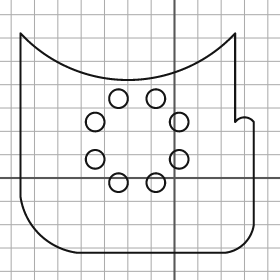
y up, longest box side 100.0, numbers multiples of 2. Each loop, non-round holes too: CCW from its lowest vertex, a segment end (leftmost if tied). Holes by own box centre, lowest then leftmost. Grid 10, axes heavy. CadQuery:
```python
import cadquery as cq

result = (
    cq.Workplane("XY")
    .moveTo(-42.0, -32.0)
    .lineTo(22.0, -32.0)
    .threePointArc((30.0, -28.0), (34.0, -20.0))
    .lineTo(34.0, 24.0)
    .threePointArc((30.0, 26.0), (26.0, 24.0))
    .lineTo(26.0, 62.0)
    .threePointArc((-20.0, 42.0), (-66.0, 62.0))
    .lineTo(-66.0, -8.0)
    .threePointArc((-58.0, -24.0), (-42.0, -32.0))
    .close()
    .moveTo(-24.0, -2.0)
    .circle(4.0)
    .moveTo(-8.0, -2.0)
    .circle(4.0)
    .moveTo(-34.0, 8.0)
    .circle(4.0)
    .moveTo(2.0, 8.0)
    .circle(4.0)
    .moveTo(-34.0, 24.0)
    .circle(4.0)
    .moveTo(2.0, 24.0)
    .circle(4.0)
    .moveTo(-24.0, 34.0)
    .circle(4.0)
    .moveTo(-8.0, 34.0)
    .circle(4.0)
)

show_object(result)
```